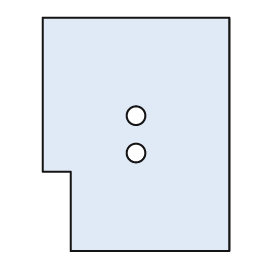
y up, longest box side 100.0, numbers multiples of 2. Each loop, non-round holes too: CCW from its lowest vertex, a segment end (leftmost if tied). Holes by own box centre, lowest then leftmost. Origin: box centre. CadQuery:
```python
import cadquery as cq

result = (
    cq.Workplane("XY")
    .moveTo(-28.0, -50.0)
    .lineTo(40.0, -50.0)
    .lineTo(40.0, 50.0)
    .lineTo(-40.0, 50.0)
    .lineTo(-40.0, -16.0)
    .lineTo(-28.0, -16.0)
    .close()
    .moveTo(0.0, -8.0)
    .circle(4.0)
    .moveTo(0.0, 8.0)
    .circle(4.0)
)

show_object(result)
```